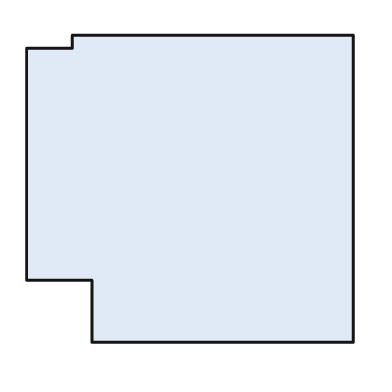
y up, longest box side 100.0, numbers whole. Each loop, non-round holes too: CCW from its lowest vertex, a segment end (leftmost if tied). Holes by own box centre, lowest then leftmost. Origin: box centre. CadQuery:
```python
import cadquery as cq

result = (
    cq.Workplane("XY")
    .moveTo(-30.0, -47.0)
    .lineTo(50.0, -47.0)
    .lineTo(50.0, 47.0)
    .lineTo(-36.0, 47.0)
    .lineTo(-36.0, 43.0)
    .lineTo(-50.0, 43.0)
    .lineTo(-50.0, -28.0)
    .lineTo(-30.0, -28.0)
    .close()
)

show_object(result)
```